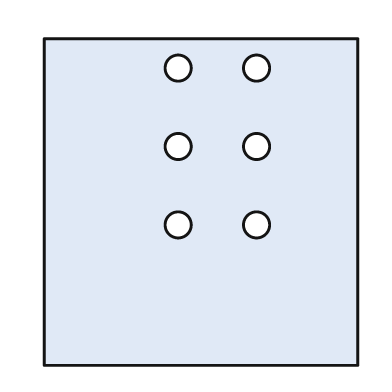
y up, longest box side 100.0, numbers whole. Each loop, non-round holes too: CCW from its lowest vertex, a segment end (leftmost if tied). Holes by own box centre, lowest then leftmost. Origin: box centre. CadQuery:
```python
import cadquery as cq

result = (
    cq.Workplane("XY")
    .moveTo(-48.0, -50.0)
    .lineTo(48.0, -50.0)
    .lineTo(48.0, 50.0)
    .lineTo(-48.0, 50.0)
    .close()
    .moveTo(-7.0, -7.0)
    .circle(4.0)
    .moveTo(17.0, -7.0)
    .circle(4.0)
    .moveTo(-7.0, 17.0)
    .circle(4.0)
    .moveTo(17.0, 17.0)
    .circle(4.0)
    .moveTo(-7.0, 41.0)
    .circle(4.0)
    .moveTo(17.0, 41.0)
    .circle(4.0)
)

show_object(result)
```